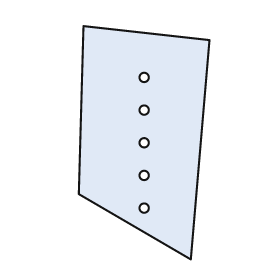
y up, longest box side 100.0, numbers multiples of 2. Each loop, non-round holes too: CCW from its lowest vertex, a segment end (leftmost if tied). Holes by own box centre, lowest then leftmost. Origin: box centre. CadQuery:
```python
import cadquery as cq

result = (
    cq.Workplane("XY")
    .moveTo(20.0, -50.0)
    .lineTo(28.0, 44.0)
    .lineTo(-26.0, 50.0)
    .lineTo(-28.0, -22.0)
    .close()
    .moveTo(0.0, -28.0)
    .circle(2.0)
    .moveTo(0.0, -14.0)
    .circle(2.0)
    .moveTo(0.0, 0.0)
    .circle(2.0)
    .moveTo(0.0, 14.0)
    .circle(2.0)
    .moveTo(0.0, 28.0)
    .circle(2.0)
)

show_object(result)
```